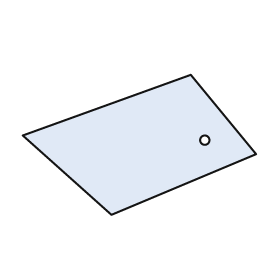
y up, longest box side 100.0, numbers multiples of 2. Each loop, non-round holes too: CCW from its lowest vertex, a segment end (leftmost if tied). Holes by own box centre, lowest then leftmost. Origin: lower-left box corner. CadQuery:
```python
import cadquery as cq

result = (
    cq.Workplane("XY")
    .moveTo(38.0, 0.0)
    .lineTo(100.0, 26.0)
    .lineTo(72.0, 60.0)
    .lineTo(0.0, 34.0)
    .close()
    .moveTo(78.0, 32.0)
    .circle(2.0)
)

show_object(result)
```